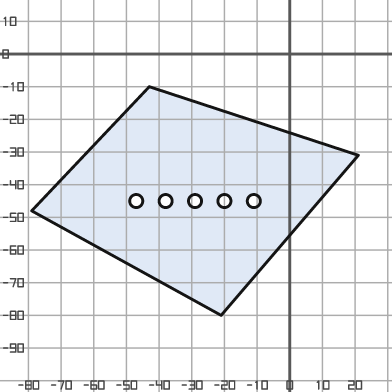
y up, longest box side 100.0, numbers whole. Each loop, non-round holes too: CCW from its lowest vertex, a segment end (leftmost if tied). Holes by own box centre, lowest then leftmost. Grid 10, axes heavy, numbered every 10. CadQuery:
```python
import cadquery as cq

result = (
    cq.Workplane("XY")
    .moveTo(-21.0, -80.0)
    .lineTo(21.0, -31.0)
    .lineTo(-43.0, -10.0)
    .lineTo(-79.0, -48.0)
    .close()
    .moveTo(-47.0, -45.0)
    .circle(2.0)
    .moveTo(-38.0, -45.0)
    .circle(2.0)
    .moveTo(-29.0, -45.0)
    .circle(2.0)
    .moveTo(-20.0, -45.0)
    .circle(2.0)
    .moveTo(-11.0, -45.0)
    .circle(2.0)
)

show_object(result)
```